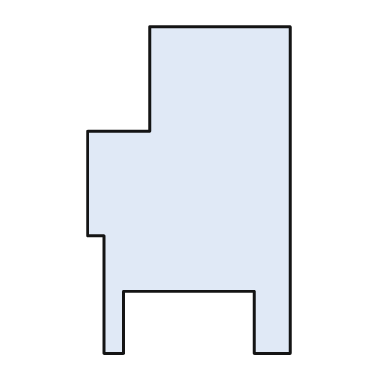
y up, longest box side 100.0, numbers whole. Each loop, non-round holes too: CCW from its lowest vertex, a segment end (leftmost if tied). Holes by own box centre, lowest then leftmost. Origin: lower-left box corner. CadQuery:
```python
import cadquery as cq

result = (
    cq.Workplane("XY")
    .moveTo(5.0, 0.0)
    .lineTo(11.0, 0.0)
    .lineTo(11.0, 19.0)
    .lineTo(51.0, 19.0)
    .lineTo(51.0, 0.0)
    .lineTo(62.0, 0.0)
    .lineTo(62.0, 100.0)
    .lineTo(19.0, 100.0)
    .lineTo(19.0, 68.0)
    .lineTo(0.0, 68.0)
    .lineTo(0.0, 36.0)
    .lineTo(5.0, 36.0)
    .close()
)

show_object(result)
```